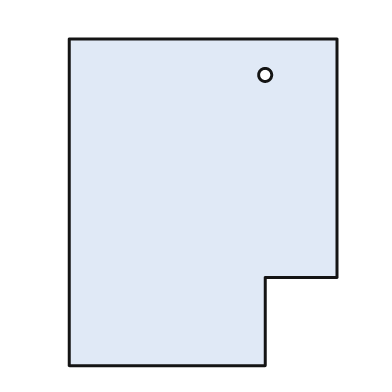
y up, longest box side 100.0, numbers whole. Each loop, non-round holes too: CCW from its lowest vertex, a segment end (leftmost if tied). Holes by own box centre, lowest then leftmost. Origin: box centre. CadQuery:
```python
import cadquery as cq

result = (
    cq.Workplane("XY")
    .moveTo(-41.0, -50.0)
    .lineTo(19.0, -50.0)
    .lineTo(19.0, -23.0)
    .lineTo(41.0, -23.0)
    .lineTo(41.0, 50.0)
    .lineTo(-41.0, 50.0)
    .close()
    .moveTo(19.0, 39.0)
    .circle(2.0)
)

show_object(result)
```